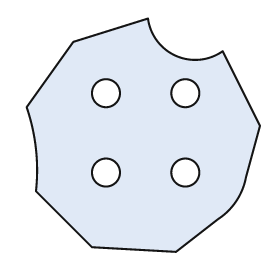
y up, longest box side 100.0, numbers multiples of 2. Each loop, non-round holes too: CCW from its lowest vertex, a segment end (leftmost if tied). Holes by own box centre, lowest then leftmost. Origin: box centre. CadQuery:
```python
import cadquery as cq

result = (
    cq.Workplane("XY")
    .moveTo(14.0, -50.0)
    .lineTo(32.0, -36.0)
    .threePointArc((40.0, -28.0), (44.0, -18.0))
    .lineTo(50.0, 4.0)
    .lineTo(34.0, 36.0)
    .threePointArc((14.0, 34.0), (2.0, 50.0))
    .lineTo(-30.0, 40.0)
    .lineTo(-50.0, 12.0)
    .threePointArc((-46.0, -6.0), (-46.0, -24.0))
    .lineTo(-22.0, -48.0)
    .close()
    .moveTo(-16.0, -16.0)
    .circle(6.0)
    .moveTo(18.0, -16.0)
    .circle(6.0)
    .moveTo(-16.0, 18.0)
    .circle(6.0)
    .moveTo(18.0, 18.0)
    .circle(6.0)
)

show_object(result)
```